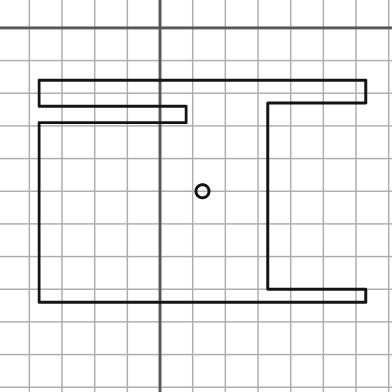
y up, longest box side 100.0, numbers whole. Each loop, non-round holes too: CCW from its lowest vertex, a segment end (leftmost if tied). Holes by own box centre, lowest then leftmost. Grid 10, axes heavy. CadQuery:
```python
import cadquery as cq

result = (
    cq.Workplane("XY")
    .moveTo(-37.0, -84.0)
    .lineTo(63.0, -84.0)
    .lineTo(63.0, -80.0)
    .lineTo(33.0, -80.0)
    .lineTo(33.0, -23.0)
    .lineTo(63.0, -23.0)
    .lineTo(63.0, -16.0)
    .lineTo(-37.0, -16.0)
    .lineTo(-37.0, -24.0)
    .lineTo(8.0, -24.0)
    .lineTo(8.0, -29.0)
    .lineTo(-37.0, -29.0)
    .close()
    .moveTo(13.0, -50.0)
    .circle(2.0)
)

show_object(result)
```